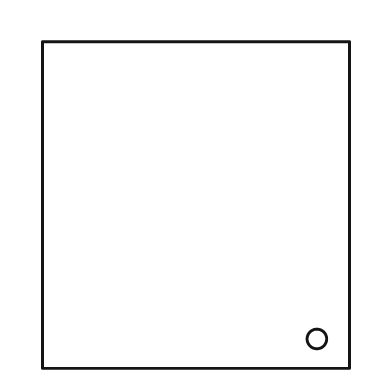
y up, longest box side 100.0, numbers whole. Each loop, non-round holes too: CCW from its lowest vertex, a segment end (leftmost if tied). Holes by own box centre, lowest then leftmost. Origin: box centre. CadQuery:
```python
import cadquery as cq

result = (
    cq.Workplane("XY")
    .moveTo(-47.0, -50.0)
    .lineTo(47.0, -50.0)
    .lineTo(47.0, 50.0)
    .lineTo(-47.0, 50.0)
    .close()
    .moveTo(37.0, -41.0)
    .circle(3.0)
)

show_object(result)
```